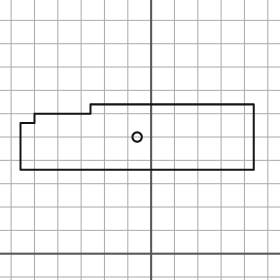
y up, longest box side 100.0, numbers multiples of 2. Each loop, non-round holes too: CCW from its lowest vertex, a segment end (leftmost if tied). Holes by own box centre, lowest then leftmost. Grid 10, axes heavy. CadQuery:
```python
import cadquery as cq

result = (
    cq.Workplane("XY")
    .moveTo(-56.0, 36.0)
    .lineTo(44.0, 36.0)
    .lineTo(44.0, 64.0)
    .lineTo(-26.0, 64.0)
    .lineTo(-26.0, 60.0)
    .lineTo(-50.0, 60.0)
    .lineTo(-50.0, 56.0)
    .lineTo(-56.0, 56.0)
    .close()
    .moveTo(-6.0, 50.0)
    .circle(2.0)
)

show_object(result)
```